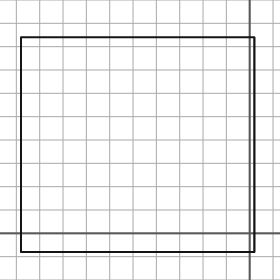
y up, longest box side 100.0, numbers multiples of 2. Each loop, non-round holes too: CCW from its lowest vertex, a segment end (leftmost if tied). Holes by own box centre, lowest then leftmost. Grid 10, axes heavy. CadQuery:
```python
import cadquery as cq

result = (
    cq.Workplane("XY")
    .moveTo(-98.0, -8.0)
    .lineTo(2.0, -8.0)
    .lineTo(2.0, 84.0)
    .lineTo(-98.0, 84.0)
    .close()
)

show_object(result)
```